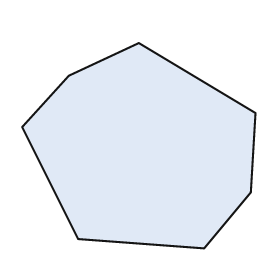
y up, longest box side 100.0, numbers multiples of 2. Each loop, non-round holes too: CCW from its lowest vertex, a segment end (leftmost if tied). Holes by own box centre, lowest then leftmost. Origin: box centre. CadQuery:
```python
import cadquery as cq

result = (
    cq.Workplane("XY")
    .moveTo(28.0, -44.0)
    .lineTo(48.0, -20.0)
    .lineTo(50.0, 14.0)
    .lineTo(0.0, 44.0)
    .lineTo(-30.0, 30.0)
    .lineTo(-50.0, 8.0)
    .lineTo(-26.0, -40.0)
    .close()
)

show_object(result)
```